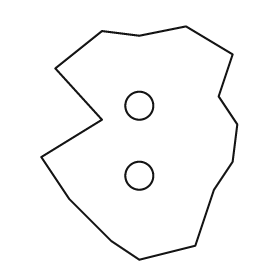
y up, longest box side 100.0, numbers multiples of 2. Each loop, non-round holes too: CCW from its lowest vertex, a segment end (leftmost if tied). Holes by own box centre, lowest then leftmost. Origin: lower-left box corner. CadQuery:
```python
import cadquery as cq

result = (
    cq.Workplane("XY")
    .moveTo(42.0, 0.0)
    .lineTo(66.0, 6.0)
    .lineTo(74.0, 30.0)
    .lineTo(82.0, 42.0)
    .lineTo(84.0, 58.0)
    .lineTo(76.0, 70.0)
    .lineTo(82.0, 88.0)
    .lineTo(62.0, 100.0)
    .lineTo(42.0, 96.0)
    .lineTo(26.0, 98.0)
    .lineTo(6.0, 82.0)
    .lineTo(26.0, 60.0)
    .lineTo(0.0, 44.0)
    .lineTo(12.0, 26.0)
    .lineTo(30.0, 8.0)
    .close()
    .moveTo(42.0, 36.0)
    .circle(6.0)
    .moveTo(42.0, 66.0)
    .circle(6.0)
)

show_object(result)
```